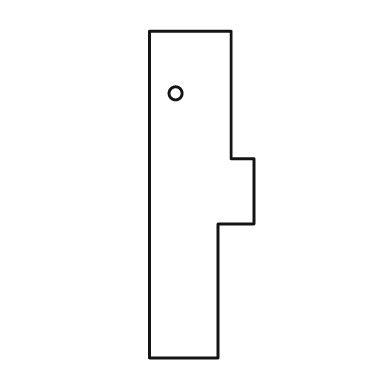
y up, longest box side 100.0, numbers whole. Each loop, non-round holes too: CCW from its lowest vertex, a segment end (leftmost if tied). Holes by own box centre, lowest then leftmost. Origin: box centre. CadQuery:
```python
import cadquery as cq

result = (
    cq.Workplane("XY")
    .moveTo(-16.0, -50.0)
    .lineTo(5.0, -50.0)
    .lineTo(5.0, -9.0)
    .lineTo(16.0, -9.0)
    .lineTo(16.0, 11.0)
    .lineTo(9.0, 11.0)
    .lineTo(9.0, 50.0)
    .lineTo(-16.0, 50.0)
    .close()
    .moveTo(-8.0, 31.0)
    .circle(2.0)
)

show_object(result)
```